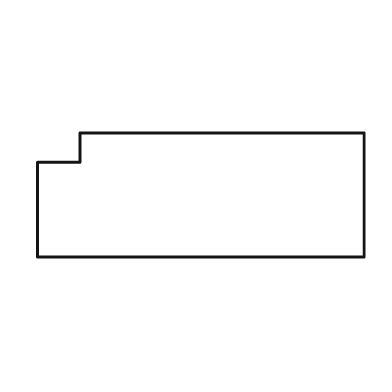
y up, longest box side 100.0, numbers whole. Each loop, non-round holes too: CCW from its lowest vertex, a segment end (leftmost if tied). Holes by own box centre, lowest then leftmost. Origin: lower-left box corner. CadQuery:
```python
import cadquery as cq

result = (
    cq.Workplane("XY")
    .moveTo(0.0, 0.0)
    .lineTo(100.0, 0.0)
    .lineTo(100.0, 38.0)
    .lineTo(13.0, 38.0)
    .lineTo(13.0, 29.0)
    .lineTo(0.0, 29.0)
    .close()
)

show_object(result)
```